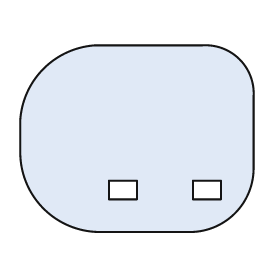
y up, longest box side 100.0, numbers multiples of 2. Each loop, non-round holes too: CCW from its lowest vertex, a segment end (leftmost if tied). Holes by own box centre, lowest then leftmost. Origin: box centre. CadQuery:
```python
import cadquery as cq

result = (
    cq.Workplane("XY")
    .moveTo(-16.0, -40.0)
    .lineTo(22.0, -40.0)
    .threePointArc((42.0, -32.0), (50.0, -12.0))
    .lineTo(50.0, 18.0)
    .threePointArc((44.0, 34.0), (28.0, 40.0))
    .lineTo(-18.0, 40.0)
    .threePointArc((-40.0, 30.0), (-50.0, 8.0))
    .lineTo(-50.0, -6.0)
    .threePointArc((-40.0, -30.0), (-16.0, -40.0))
    .close()
    .moveTo(-12.0, -26.0)
    .lineTo(0.0, -26.0)
    .lineTo(0.0, -18.0)
    .lineTo(-12.0, -18.0)
    .close()
    .moveTo(24.0, -26.0)
    .lineTo(36.0, -26.0)
    .lineTo(36.0, -18.0)
    .lineTo(24.0, -18.0)
    .close()
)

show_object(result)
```